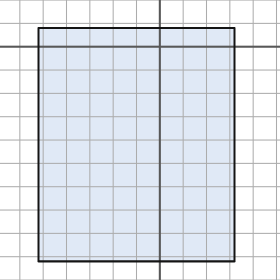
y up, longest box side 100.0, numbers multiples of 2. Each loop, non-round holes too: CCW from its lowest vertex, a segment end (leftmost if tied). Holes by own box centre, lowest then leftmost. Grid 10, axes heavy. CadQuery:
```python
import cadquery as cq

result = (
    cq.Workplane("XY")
    .moveTo(-52.0, -92.0)
    .lineTo(32.0, -92.0)
    .lineTo(32.0, 8.0)
    .lineTo(-52.0, 8.0)
    .close()
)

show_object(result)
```